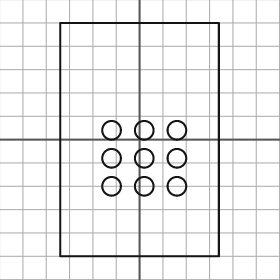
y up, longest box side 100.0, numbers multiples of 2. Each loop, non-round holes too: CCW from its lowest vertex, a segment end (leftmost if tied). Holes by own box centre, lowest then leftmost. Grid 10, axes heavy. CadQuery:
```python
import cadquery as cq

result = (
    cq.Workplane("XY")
    .moveTo(-34.0, -50.0)
    .lineTo(34.0, -50.0)
    .lineTo(34.0, 50.0)
    .lineTo(-34.0, 50.0)
    .close()
    .moveTo(-12.0, -20.0)
    .circle(4.0)
    .moveTo(2.0, -20.0)
    .circle(4.0)
    .moveTo(16.0, -20.0)
    .circle(4.0)
    .moveTo(-12.0, -8.0)
    .circle(4.0)
    .moveTo(2.0, -8.0)
    .circle(4.0)
    .moveTo(16.0, -8.0)
    .circle(4.0)
    .moveTo(-12.0, 4.0)
    .circle(4.0)
    .moveTo(2.0, 4.0)
    .circle(4.0)
    .moveTo(16.0, 4.0)
    .circle(4.0)
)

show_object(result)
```